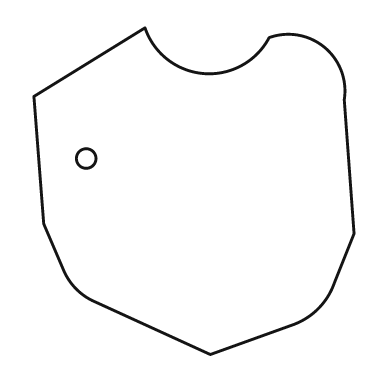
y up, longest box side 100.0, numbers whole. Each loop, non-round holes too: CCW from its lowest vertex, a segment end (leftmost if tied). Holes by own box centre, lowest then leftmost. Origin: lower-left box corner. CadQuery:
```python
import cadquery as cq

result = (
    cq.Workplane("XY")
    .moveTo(54.0, 0.0)
    .lineTo(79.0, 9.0)
    .threePointArc((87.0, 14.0), (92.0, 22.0))
    .lineTo(98.0, 37.0)
    .lineTo(95.0, 78.0)
    .threePointArc((89.0, 94.0), (72.0, 97.0))
    .threePointArc((52.0, 86.0), (34.0, 100.0))
    .lineTo(0.0, 79.0)
    .lineTo(3.0, 40.0)
    .lineTo(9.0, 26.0)
    .threePointArc((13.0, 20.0), (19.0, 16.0))
    .close()
    .moveTo(16.0, 60.0)
    .circle(3.0)
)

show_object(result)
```